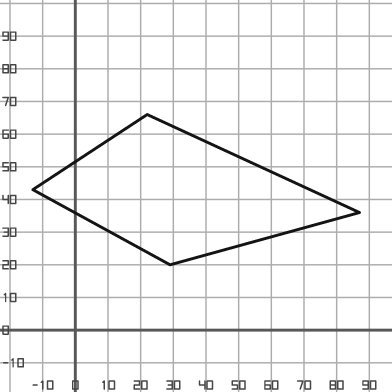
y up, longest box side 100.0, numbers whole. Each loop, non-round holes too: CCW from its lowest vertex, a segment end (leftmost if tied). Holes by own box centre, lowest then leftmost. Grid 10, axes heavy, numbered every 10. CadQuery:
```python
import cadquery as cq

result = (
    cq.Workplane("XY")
    .moveTo(29.0, 20.0)
    .lineTo(87.0, 36.0)
    .lineTo(22.0, 66.0)
    .lineTo(-13.0, 43.0)
    .close()
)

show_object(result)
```